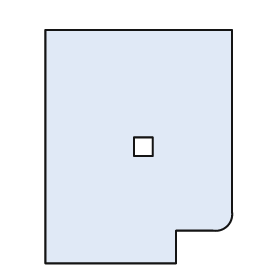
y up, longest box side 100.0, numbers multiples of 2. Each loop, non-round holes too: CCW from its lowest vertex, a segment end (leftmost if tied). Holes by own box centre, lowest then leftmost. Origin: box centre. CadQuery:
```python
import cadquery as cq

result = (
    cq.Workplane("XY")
    .moveTo(-40.0, -50.0)
    .lineTo(16.0, -50.0)
    .lineTo(16.0, -36.0)
    .lineTo(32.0, -36.0)
    .threePointArc((38.0, -34.0), (40.0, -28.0))
    .lineTo(40.0, 50.0)
    .lineTo(-40.0, 50.0)
    .close()
    .moveTo(-2.0, -4.0)
    .lineTo(6.0, -4.0)
    .lineTo(6.0, 4.0)
    .lineTo(-2.0, 4.0)
    .close()
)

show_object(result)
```